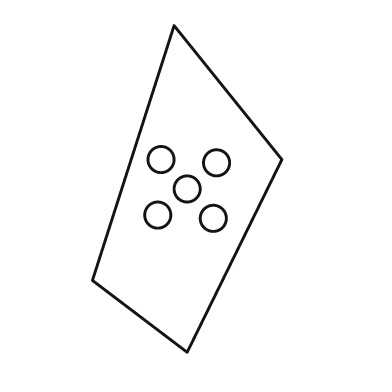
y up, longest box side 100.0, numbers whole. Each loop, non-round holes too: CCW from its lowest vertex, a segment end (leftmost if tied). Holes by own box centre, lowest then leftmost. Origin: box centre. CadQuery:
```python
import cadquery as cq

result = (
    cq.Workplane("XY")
    .moveTo(0.0, -50.0)
    .lineTo(29.0, 9.0)
    .lineTo(-4.0, 50.0)
    .lineTo(-29.0, -28.0)
    .close()
    .moveTo(8.0, -9.0)
    .circle(4.0)
    .moveTo(-9.0, -8.0)
    .circle(4.0)
    .moveTo(0.0, 0.0)
    .circle(4.0)
    .moveTo(9.0, 8.0)
    .circle(4.0)
    .moveTo(-8.0, 9.0)
    .circle(4.0)
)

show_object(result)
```